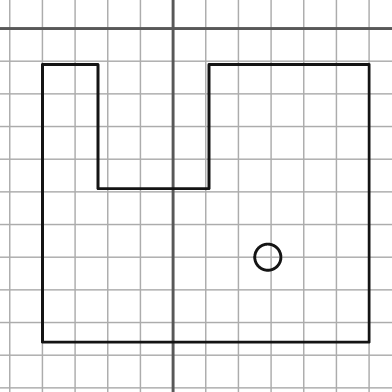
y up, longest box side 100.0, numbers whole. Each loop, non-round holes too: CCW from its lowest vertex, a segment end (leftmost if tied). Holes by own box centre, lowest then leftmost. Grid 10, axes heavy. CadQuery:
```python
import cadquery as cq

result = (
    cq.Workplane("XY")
    .moveTo(-40.0, -96.0)
    .lineTo(60.0, -96.0)
    .lineTo(60.0, -11.0)
    .lineTo(11.0, -11.0)
    .lineTo(11.0, -49.0)
    .lineTo(-23.0, -49.0)
    .lineTo(-23.0, -11.0)
    .lineTo(-40.0, -11.0)
    .close()
    .moveTo(29.0, -70.0)
    .circle(4.0)
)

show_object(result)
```